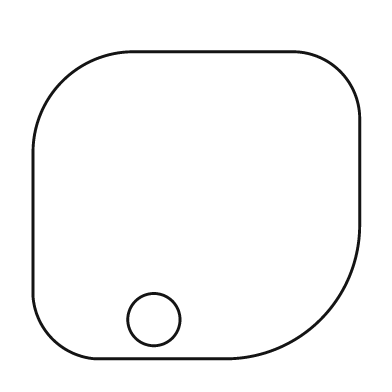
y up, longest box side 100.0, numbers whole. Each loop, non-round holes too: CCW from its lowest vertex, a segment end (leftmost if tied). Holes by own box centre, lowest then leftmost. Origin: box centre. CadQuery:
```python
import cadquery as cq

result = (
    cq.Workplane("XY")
    .moveTo(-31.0, -47.0)
    .lineTo(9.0, -47.0)
    .threePointArc((38.0, -35.0), (50.0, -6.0))
    .lineTo(50.0, 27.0)
    .threePointArc((44.0, 41.0), (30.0, 47.0))
    .lineTo(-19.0, 47.0)
    .threePointArc((-41.0, 38.0), (-50.0, 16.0))
    .lineTo(-50.0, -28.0)
    .threePointArc((-44.0, -41.0), (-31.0, -47.0))
    .close()
    .moveTo(-13.0, -35.0)
    .circle(8.0)
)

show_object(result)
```